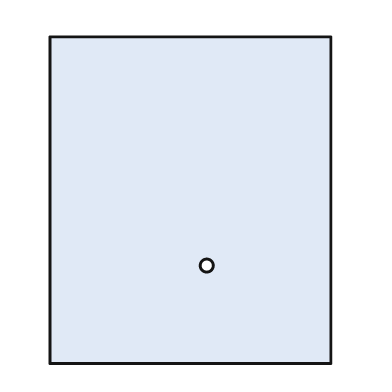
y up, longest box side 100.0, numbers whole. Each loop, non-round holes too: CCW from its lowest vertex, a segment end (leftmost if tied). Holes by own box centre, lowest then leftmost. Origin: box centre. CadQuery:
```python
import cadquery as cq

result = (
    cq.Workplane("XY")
    .moveTo(-43.0, -50.0)
    .lineTo(43.0, -50.0)
    .lineTo(43.0, 50.0)
    .lineTo(-43.0, 50.0)
    .close()
    .moveTo(5.0, -20.0)
    .circle(2.0)
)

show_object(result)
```